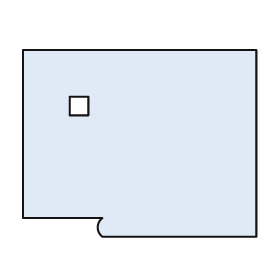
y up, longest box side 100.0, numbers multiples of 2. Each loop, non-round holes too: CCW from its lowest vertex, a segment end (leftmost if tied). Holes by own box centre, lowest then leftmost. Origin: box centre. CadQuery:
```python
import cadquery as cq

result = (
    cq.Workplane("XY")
    .moveTo(-16.0, -40.0)
    .lineTo(50.0, -40.0)
    .lineTo(50.0, 40.0)
    .lineTo(-50.0, 40.0)
    .lineTo(-50.0, -32.0)
    .lineTo(-16.0, -32.0)
    .threePointArc((-18.0, -36.0), (-16.0, -40.0))
    .close()
    .moveTo(-30.0, 12.0)
    .lineTo(-22.0, 12.0)
    .lineTo(-22.0, 20.0)
    .lineTo(-30.0, 20.0)
    .close()
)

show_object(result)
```